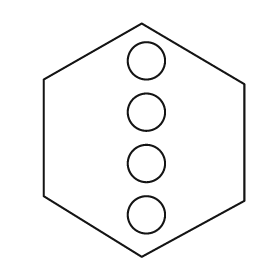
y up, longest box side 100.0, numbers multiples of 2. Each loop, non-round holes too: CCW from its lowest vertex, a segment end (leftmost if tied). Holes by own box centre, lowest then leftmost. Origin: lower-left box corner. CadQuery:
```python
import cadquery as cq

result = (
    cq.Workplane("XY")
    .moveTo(42.0, 0.0)
    .lineTo(86.0, 24.0)
    .lineTo(86.0, 74.0)
    .lineTo(42.0, 100.0)
    .lineTo(0.0, 76.0)
    .lineTo(0.0, 26.0)
    .close()
    .moveTo(44.0, 18.0)
    .circle(8.0)
    .moveTo(44.0, 40.0)
    .circle(8.0)
    .moveTo(44.0, 62.0)
    .circle(8.0)
    .moveTo(44.0, 84.0)
    .circle(8.0)
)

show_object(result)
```